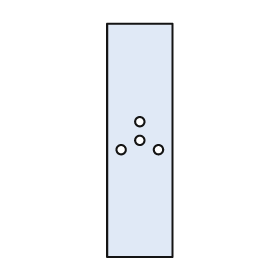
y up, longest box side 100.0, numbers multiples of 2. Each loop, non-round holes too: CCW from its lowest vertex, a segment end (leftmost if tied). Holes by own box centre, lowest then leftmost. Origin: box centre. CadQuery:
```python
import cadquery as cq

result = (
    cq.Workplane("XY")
    .moveTo(-14.0, -50.0)
    .lineTo(14.0, -50.0)
    .lineTo(14.0, 50.0)
    .lineTo(-14.0, 50.0)
    .close()
    .moveTo(-8.0, -4.0)
    .circle(2.0)
    .moveTo(8.0, -4.0)
    .circle(2.0)
    .moveTo(0.0, 0.0)
    .circle(2.0)
    .moveTo(0.0, 8.0)
    .circle(2.0)
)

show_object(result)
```